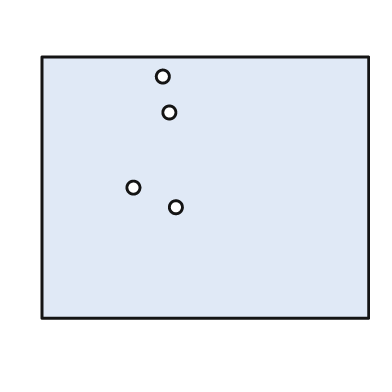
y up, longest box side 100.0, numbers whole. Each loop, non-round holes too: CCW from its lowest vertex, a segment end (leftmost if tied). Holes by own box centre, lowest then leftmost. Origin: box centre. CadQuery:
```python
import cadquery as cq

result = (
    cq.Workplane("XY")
    .moveTo(-50.0, -40.0)
    .lineTo(50.0, -40.0)
    .lineTo(50.0, 40.0)
    .lineTo(-50.0, 40.0)
    .close()
    .moveTo(-9.0, -6.0)
    .circle(2.0)
    .moveTo(-22.0, 0.0)
    .circle(2.0)
    .moveTo(-11.0, 23.0)
    .circle(2.0)
    .moveTo(-13.0, 34.0)
    .circle(2.0)
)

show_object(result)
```